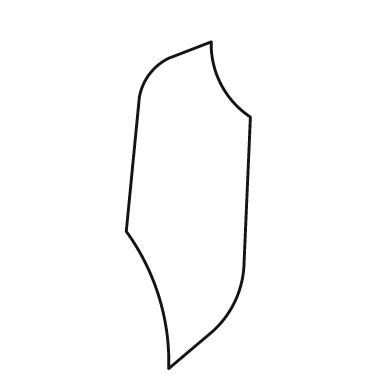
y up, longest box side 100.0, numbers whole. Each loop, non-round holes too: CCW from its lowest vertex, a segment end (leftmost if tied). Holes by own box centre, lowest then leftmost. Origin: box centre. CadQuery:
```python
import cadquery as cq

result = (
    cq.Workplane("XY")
    .moveTo(-6.0, -50.0)
    .lineTo(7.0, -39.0)
    .threePointArc((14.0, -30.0), (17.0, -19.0))
    .lineTo(19.0, 27.0)
    .threePointArc((10.0, 37.0), (7.0, 50.0))
    .lineTo(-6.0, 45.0)
    .threePointArc((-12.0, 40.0), (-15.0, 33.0))
    .lineTo(-19.0, -8.0)
    .threePointArc((-9.0, -28.0), (-6.0, -50.0))
    .close()
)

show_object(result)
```